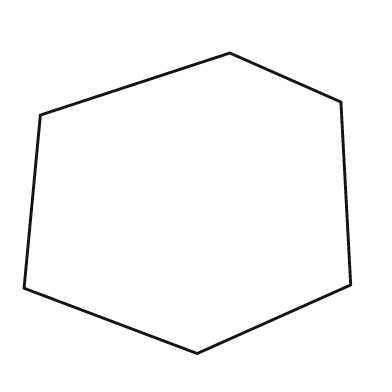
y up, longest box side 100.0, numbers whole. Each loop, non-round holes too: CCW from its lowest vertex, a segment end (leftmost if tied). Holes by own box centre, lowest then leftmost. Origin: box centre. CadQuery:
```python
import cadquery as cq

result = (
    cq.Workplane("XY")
    .moveTo(3.0, -46.0)
    .lineTo(50.0, -25.0)
    .lineTo(47.0, 31.0)
    .lineTo(13.0, 46.0)
    .lineTo(-45.0, 27.0)
    .lineTo(-50.0, -26.0)
    .close()
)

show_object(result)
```